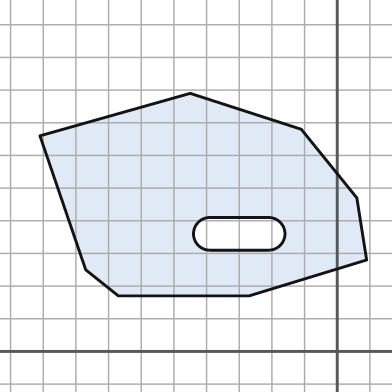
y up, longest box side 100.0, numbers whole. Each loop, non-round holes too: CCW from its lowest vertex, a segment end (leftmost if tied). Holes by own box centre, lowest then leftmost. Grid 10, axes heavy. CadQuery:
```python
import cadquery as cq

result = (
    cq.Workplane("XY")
    .moveTo(-67.0, 17.0)
    .lineTo(-27.0, 17.0)
    .lineTo(9.0, 28.0)
    .lineTo(6.0, 47.0)
    .lineTo(-11.0, 68.0)
    .lineTo(-45.0, 79.0)
    .lineTo(-91.0, 66.0)
    .lineTo(-77.0, 25.0)
    .close()
    .moveTo(-39.0, 31.0)
    .lineTo(-21.0, 31.0)
    .threePointArc((-16.0, 36.0), (-21.0, 41.0))
    .lineTo(-39.0, 41.0)
    .threePointArc((-44.0, 36.0), (-39.0, 31.0))
    .close()
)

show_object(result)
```